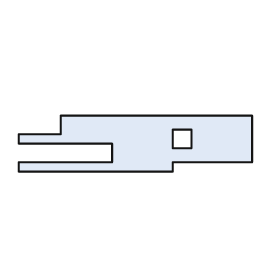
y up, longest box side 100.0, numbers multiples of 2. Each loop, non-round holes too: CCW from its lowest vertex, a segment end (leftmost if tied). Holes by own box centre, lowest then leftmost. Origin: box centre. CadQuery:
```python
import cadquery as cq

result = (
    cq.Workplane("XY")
    .moveTo(-50.0, -12.0)
    .lineTo(16.0, -12.0)
    .lineTo(16.0, -8.0)
    .lineTo(50.0, -8.0)
    .lineTo(50.0, 12.0)
    .lineTo(-32.0, 12.0)
    .lineTo(-32.0, 4.0)
    .lineTo(-50.0, 4.0)
    .lineTo(-50.0, 0.0)
    .lineTo(-10.0, 0.0)
    .lineTo(-10.0, -8.0)
    .lineTo(-50.0, -8.0)
    .close()
    .moveTo(16.0, -2.0)
    .lineTo(24.0, -2.0)
    .lineTo(24.0, 6.0)
    .lineTo(16.0, 6.0)
    .close()
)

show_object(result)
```